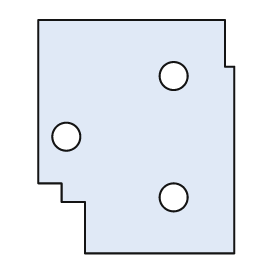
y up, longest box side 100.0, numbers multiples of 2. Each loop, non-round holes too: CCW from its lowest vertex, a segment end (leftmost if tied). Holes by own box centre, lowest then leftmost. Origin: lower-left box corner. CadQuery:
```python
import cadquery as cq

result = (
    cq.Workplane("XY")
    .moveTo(20.0, 0.0)
    .lineTo(84.0, 0.0)
    .lineTo(84.0, 80.0)
    .lineTo(80.0, 80.0)
    .lineTo(80.0, 100.0)
    .lineTo(0.0, 100.0)
    .lineTo(0.0, 30.0)
    .lineTo(10.0, 30.0)
    .lineTo(10.0, 22.0)
    .lineTo(20.0, 22.0)
    .close()
    .moveTo(58.0, 24.0)
    .circle(6.0)
    .moveTo(12.0, 50.0)
    .circle(6.0)
    .moveTo(58.0, 76.0)
    .circle(6.0)
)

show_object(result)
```